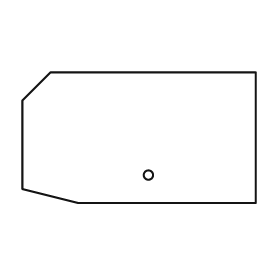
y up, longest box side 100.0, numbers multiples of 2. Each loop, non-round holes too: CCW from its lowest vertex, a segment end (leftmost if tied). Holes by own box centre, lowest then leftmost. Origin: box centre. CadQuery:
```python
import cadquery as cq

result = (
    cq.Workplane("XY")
    .moveTo(-26.0, -28.0)
    .lineTo(50.0, -28.0)
    .lineTo(50.0, 28.0)
    .lineTo(-38.0, 28.0)
    .lineTo(-50.0, 16.0)
    .lineTo(-50.0, -22.0)
    .close()
    .moveTo(4.0, -16.0)
    .circle(2.0)
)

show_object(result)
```